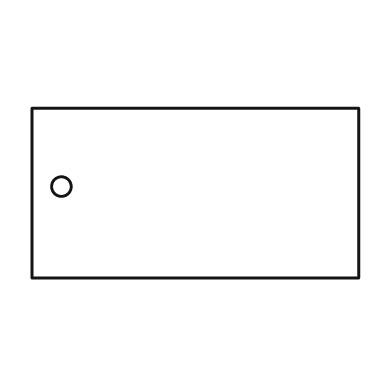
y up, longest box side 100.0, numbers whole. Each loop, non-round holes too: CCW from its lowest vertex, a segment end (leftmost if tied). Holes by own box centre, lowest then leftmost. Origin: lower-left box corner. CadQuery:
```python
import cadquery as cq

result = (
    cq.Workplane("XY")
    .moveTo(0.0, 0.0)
    .lineTo(100.0, 0.0)
    .lineTo(100.0, 52.0)
    .lineTo(0.0, 52.0)
    .close()
    .moveTo(9.0, 28.0)
    .circle(3.0)
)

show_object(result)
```